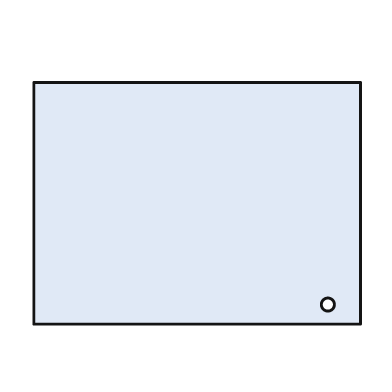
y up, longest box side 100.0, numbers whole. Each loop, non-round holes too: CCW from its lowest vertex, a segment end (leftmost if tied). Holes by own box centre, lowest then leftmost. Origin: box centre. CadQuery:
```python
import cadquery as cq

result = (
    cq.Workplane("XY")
    .moveTo(-50.0, -37.0)
    .lineTo(50.0, -37.0)
    .lineTo(50.0, 37.0)
    .lineTo(-50.0, 37.0)
    .close()
    .moveTo(40.0, -31.0)
    .circle(2.0)
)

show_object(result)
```